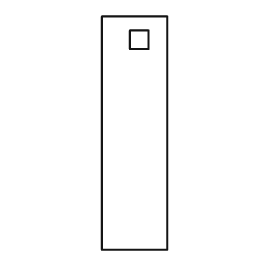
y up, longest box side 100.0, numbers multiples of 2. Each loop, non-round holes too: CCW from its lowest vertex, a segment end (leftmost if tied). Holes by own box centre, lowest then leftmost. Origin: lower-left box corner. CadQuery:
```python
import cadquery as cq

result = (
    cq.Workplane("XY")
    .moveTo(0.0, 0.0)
    .lineTo(28.0, 0.0)
    .lineTo(28.0, 100.0)
    .lineTo(0.0, 100.0)
    .close()
    .moveTo(12.0, 86.0)
    .lineTo(20.0, 86.0)
    .lineTo(20.0, 94.0)
    .lineTo(12.0, 94.0)
    .close()
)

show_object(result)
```